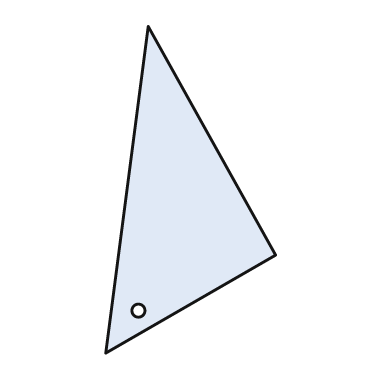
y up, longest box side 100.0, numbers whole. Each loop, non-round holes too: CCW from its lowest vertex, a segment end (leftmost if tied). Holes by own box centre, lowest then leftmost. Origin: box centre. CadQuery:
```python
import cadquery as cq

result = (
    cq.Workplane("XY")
    .moveTo(-26.0, -50.0)
    .lineTo(26.0, -20.0)
    .lineTo(-13.0, 50.0)
    .close()
    .moveTo(-16.0, -37.0)
    .circle(2.0)
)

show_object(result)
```